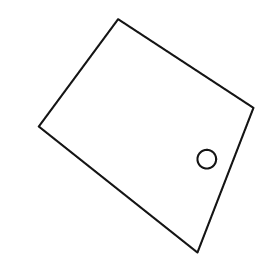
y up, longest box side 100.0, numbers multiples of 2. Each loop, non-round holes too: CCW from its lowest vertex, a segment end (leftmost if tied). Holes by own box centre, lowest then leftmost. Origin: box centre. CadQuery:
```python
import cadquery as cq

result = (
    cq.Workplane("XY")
    .moveTo(22.0, -50.0)
    .lineTo(46.0, 12.0)
    .lineTo(-12.0, 50.0)
    .lineTo(-46.0, 4.0)
    .close()
    .moveTo(26.0, -10.0)
    .circle(4.0)
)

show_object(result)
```